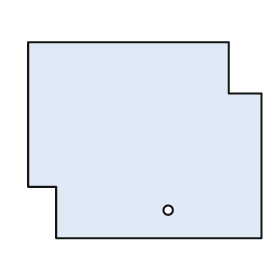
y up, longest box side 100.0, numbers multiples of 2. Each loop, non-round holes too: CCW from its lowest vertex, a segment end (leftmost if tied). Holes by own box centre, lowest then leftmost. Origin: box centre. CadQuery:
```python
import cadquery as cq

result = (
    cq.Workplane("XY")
    .moveTo(-38.0, -42.0)
    .lineTo(50.0, -42.0)
    .lineTo(50.0, 20.0)
    .lineTo(36.0, 20.0)
    .lineTo(36.0, 42.0)
    .lineTo(-50.0, 42.0)
    .lineTo(-50.0, -20.0)
    .lineTo(-38.0, -20.0)
    .close()
    .moveTo(10.0, -30.0)
    .circle(2.0)
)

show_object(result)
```